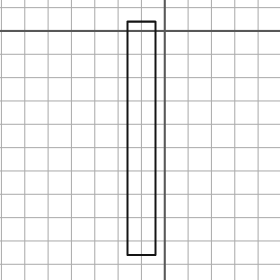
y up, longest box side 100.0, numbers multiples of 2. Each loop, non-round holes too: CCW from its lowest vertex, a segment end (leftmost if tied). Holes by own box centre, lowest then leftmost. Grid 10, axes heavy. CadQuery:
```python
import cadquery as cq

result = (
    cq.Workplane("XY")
    .moveTo(-16.0, -96.0)
    .lineTo(-4.0, -96.0)
    .lineTo(-4.0, 4.0)
    .lineTo(-16.0, 4.0)
    .close()
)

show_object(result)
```